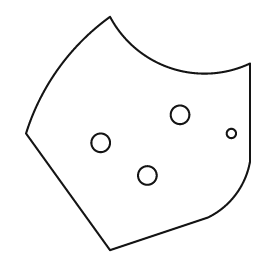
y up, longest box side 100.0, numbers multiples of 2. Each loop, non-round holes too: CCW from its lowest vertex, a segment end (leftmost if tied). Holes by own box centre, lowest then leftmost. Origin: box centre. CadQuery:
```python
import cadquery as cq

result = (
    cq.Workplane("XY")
    .moveTo(-12.0, -50.0)
    .lineTo(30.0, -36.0)
    .threePointArc((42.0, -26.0), (48.0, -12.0))
    .lineTo(48.0, 30.0)
    .threePointArc((14.0, 28.0), (-12.0, 50.0))
    .threePointArc((-34.0, 28.0), (-48.0, 0.0))
    .close()
    .moveTo(4.0, -18.0)
    .circle(4.0)
    .moveTo(-16.0, -4.0)
    .circle(4.0)
    .moveTo(40.0, 0.0)
    .circle(2.0)
    .moveTo(18.0, 8.0)
    .circle(4.0)
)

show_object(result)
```